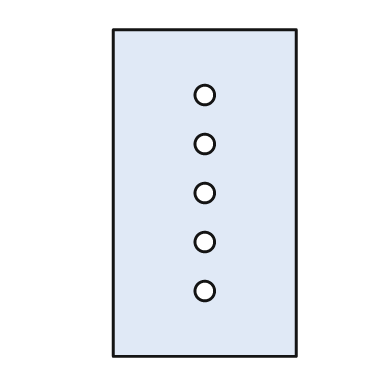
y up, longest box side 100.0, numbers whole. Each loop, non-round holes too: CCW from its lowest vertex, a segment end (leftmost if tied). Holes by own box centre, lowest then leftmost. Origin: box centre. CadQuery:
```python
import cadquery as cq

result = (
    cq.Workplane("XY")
    .moveTo(-28.0, -50.0)
    .lineTo(28.0, -50.0)
    .lineTo(28.0, 50.0)
    .lineTo(-28.0, 50.0)
    .close()
    .moveTo(0.0, -30.0)
    .circle(3.0)
    .moveTo(0.0, -15.0)
    .circle(3.0)
    .moveTo(0.0, 0.0)
    .circle(3.0)
    .moveTo(0.0, 15.0)
    .circle(3.0)
    .moveTo(0.0, 30.0)
    .circle(3.0)
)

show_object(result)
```